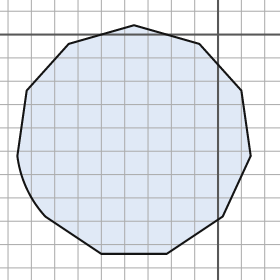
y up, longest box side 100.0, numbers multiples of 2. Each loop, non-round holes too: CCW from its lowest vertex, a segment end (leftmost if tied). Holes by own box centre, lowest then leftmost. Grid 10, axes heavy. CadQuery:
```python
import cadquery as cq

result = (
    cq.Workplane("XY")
    .moveTo(-50.0, -94.0)
    .lineTo(-22.0, -94.0)
    .lineTo(2.0, -78.0)
    .lineTo(14.0, -52.0)
    .lineTo(10.0, -24.0)
    .lineTo(-8.0, -4.0)
    .lineTo(-36.0, 4.0)
    .lineTo(-64.0, -4.0)
    .lineTo(-82.0, -24.0)
    .lineTo(-86.0, -52.0)
    .threePointArc((-82.0, -66.0), (-74.0, -78.0))
    .close()
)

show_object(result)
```